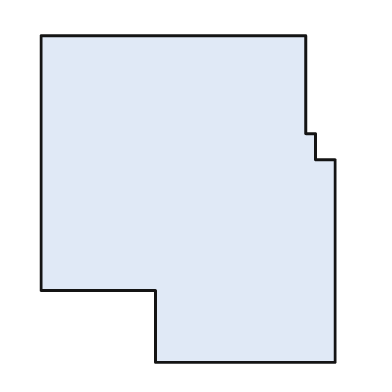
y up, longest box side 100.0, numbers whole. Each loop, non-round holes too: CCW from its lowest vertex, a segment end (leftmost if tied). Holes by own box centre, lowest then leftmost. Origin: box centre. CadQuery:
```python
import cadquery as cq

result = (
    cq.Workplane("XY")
    .moveTo(-10.0, -50.0)
    .lineTo(45.0, -50.0)
    .lineTo(45.0, 12.0)
    .lineTo(39.0, 12.0)
    .lineTo(39.0, 20.0)
    .lineTo(36.0, 20.0)
    .lineTo(36.0, 50.0)
    .lineTo(-45.0, 50.0)
    .lineTo(-45.0, -28.0)
    .lineTo(-10.0, -28.0)
    .close()
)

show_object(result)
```